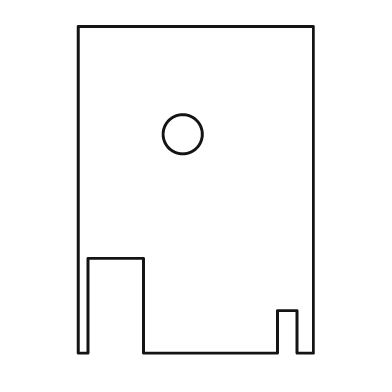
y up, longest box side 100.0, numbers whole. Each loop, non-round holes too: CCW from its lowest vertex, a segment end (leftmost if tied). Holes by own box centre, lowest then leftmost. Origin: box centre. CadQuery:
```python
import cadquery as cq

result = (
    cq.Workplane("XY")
    .moveTo(-36.0, -50.0)
    .lineTo(-33.0, -50.0)
    .lineTo(-33.0, -21.0)
    .lineTo(-16.0, -21.0)
    .lineTo(-16.0, -50.0)
    .lineTo(25.0, -50.0)
    .lineTo(25.0, -37.0)
    .lineTo(31.0, -37.0)
    .lineTo(31.0, -50.0)
    .lineTo(36.0, -50.0)
    .lineTo(36.0, 50.0)
    .lineTo(-36.0, 50.0)
    .close()
    .moveTo(-4.0, 17.0)
    .circle(6.0)
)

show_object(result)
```